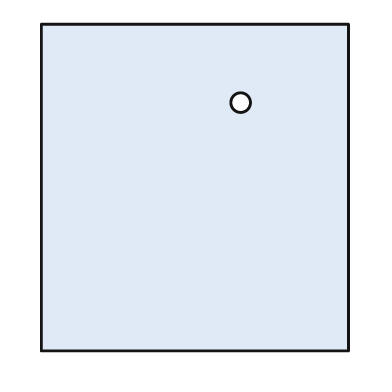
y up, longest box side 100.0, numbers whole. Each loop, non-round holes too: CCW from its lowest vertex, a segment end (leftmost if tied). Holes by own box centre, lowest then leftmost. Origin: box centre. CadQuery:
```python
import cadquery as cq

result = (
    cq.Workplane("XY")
    .moveTo(-47.0, -50.0)
    .lineTo(47.0, -50.0)
    .lineTo(47.0, 50.0)
    .lineTo(-47.0, 50.0)
    .close()
    .moveTo(14.0, 26.0)
    .circle(3.0)
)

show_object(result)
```